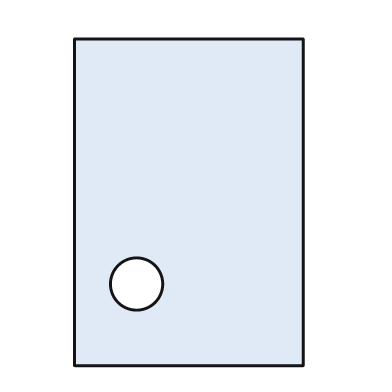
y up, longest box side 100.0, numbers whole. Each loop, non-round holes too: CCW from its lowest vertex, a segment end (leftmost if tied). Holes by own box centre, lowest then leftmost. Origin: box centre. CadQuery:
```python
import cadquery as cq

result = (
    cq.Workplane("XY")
    .moveTo(-35.0, -50.0)
    .lineTo(35.0, -50.0)
    .lineTo(35.0, 50.0)
    .lineTo(-35.0, 50.0)
    .close()
    .moveTo(-16.0, -25.0)
    .circle(8.0)
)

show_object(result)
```